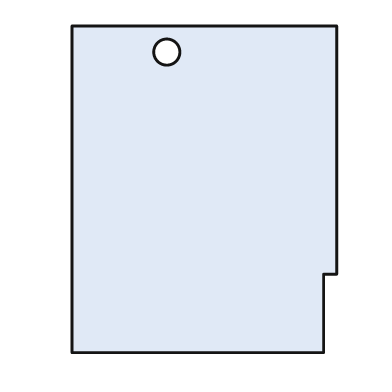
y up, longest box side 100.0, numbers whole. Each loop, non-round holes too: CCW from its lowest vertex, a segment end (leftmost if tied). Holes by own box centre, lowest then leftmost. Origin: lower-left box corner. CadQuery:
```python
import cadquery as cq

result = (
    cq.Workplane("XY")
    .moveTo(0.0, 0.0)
    .lineTo(77.0, 0.0)
    .lineTo(77.0, 24.0)
    .lineTo(81.0, 24.0)
    .lineTo(81.0, 100.0)
    .lineTo(0.0, 100.0)
    .close()
    .moveTo(29.0, 92.0)
    .circle(4.0)
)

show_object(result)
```